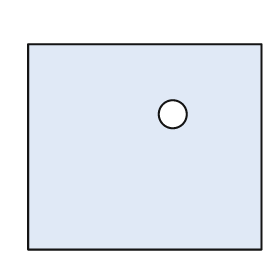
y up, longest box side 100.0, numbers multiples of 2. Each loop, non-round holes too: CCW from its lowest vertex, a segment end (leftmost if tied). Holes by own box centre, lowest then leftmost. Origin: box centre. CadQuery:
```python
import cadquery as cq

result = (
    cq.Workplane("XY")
    .moveTo(-50.0, -44.0)
    .lineTo(50.0, -44.0)
    .lineTo(50.0, 44.0)
    .lineTo(-50.0, 44.0)
    .close()
    .moveTo(12.0, 14.0)
    .circle(6.0)
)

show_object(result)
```